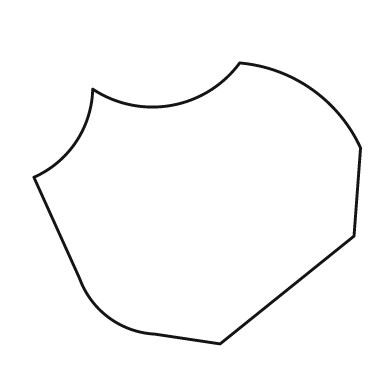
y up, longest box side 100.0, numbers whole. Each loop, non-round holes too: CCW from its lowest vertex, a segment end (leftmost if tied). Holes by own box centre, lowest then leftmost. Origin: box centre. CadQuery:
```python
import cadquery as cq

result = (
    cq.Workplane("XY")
    .moveTo(7.0, -43.0)
    .lineTo(48.0, -10.0)
    .lineTo(50.0, 17.0)
    .threePointArc((35.0, 35.0), (13.0, 43.0))
    .threePointArc((-8.0, 30.0), (-32.0, 35.0))
    .threePointArc((-37.0, 19.0), (-50.0, 8.0))
    .lineTo(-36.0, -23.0)
    .threePointArc((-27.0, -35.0), (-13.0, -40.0))
    .close()
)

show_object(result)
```